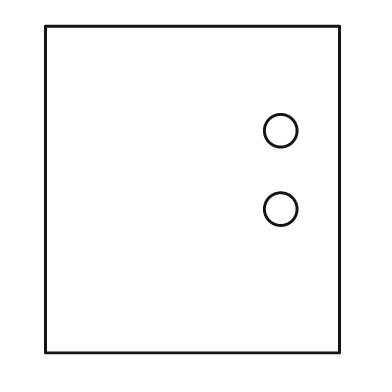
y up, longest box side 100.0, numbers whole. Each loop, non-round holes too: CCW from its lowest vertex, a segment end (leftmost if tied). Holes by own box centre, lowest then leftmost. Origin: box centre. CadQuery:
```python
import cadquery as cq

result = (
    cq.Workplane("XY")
    .moveTo(-45.0, -50.0)
    .lineTo(45.0, -50.0)
    .lineTo(45.0, 50.0)
    .lineTo(-45.0, 50.0)
    .close()
    .moveTo(27.0, -6.0)
    .circle(5.0)
    .moveTo(27.0, 18.0)
    .circle(5.0)
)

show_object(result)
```